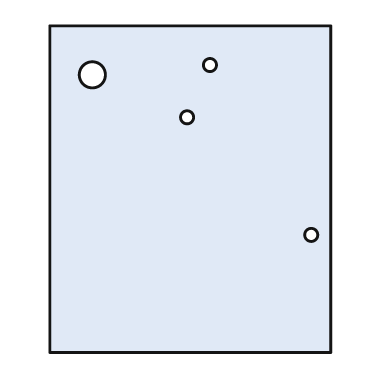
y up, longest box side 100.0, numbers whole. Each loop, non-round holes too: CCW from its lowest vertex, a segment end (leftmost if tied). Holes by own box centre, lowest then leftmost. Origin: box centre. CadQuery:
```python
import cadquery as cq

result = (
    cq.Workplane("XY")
    .moveTo(-43.0, -50.0)
    .lineTo(43.0, -50.0)
    .lineTo(43.0, 50.0)
    .lineTo(-43.0, 50.0)
    .close()
    .moveTo(37.0, -14.0)
    .circle(2.0)
    .moveTo(-1.0, 22.0)
    .circle(2.0)
    .moveTo(-30.0, 35.0)
    .circle(4.0)
    .moveTo(6.0, 38.0)
    .circle(2.0)
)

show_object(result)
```